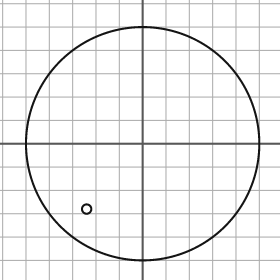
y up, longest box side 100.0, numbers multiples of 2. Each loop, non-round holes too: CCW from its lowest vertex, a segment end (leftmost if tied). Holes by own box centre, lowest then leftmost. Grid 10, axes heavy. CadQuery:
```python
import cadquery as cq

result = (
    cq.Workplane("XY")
    .moveTo(0.0, 0.0)
    .circle(50.0)
    .moveTo(-24.0, -28.0)
    .circle(2.0)
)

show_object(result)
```